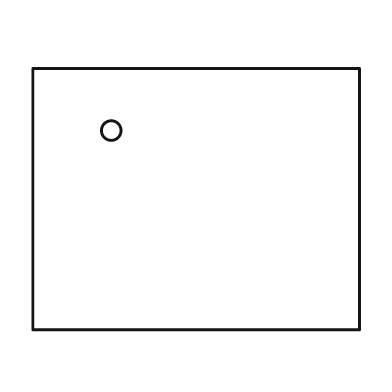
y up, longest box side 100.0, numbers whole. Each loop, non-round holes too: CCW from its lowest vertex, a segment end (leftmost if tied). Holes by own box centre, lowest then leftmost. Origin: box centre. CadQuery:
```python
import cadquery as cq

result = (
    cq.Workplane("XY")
    .moveTo(-50.0, -40.0)
    .lineTo(50.0, -40.0)
    .lineTo(50.0, 40.0)
    .lineTo(-50.0, 40.0)
    .close()
    .moveTo(-26.0, 21.0)
    .circle(3.0)
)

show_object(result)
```